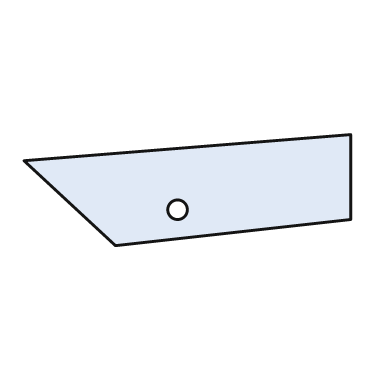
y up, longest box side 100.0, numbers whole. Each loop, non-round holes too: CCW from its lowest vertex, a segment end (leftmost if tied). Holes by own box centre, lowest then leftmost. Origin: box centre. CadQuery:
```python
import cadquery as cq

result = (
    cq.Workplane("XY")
    .moveTo(-22.0, -17.0)
    .lineTo(50.0, -9.0)
    .lineTo(50.0, 17.0)
    .lineTo(-50.0, 9.0)
    .close()
    .moveTo(-3.0, -6.0)
    .circle(3.0)
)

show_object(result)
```